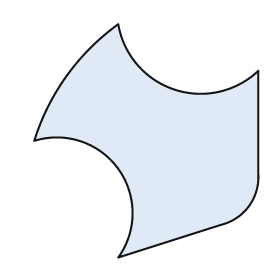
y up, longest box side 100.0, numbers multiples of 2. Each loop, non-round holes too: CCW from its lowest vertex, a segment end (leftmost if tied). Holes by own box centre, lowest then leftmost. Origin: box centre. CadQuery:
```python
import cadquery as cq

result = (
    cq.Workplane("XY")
    .moveTo(-12.0, -50.0)
    .lineTo(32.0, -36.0)
    .threePointArc((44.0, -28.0), (48.0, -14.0))
    .lineTo(48.0, 30.0)
    .threePointArc((12.0, 22.0), (-12.0, 50.0))
    .threePointArc((-34.0, 28.0), (-48.0, 0.0))
    .threePointArc((-12.0, -12.0), (-12.0, -50.0))
    .close()
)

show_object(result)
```